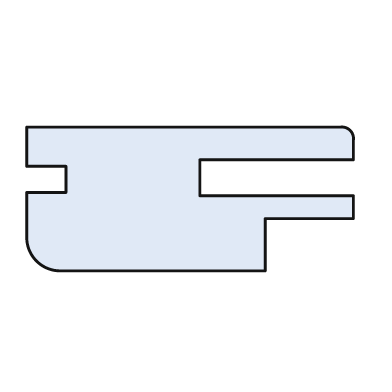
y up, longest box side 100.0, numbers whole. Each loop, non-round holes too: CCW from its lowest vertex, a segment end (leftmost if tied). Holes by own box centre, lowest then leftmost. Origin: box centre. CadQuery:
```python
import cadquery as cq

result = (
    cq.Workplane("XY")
    .moveTo(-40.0, -22.0)
    .lineTo(23.0, -22.0)
    .lineTo(23.0, -6.0)
    .lineTo(50.0, -6.0)
    .lineTo(50.0, 1.0)
    .lineTo(3.0, 1.0)
    .lineTo(3.0, 12.0)
    .lineTo(50.0, 12.0)
    .lineTo(50.0, 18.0)
    .threePointArc((49.0, 21.0), (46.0, 22.0))
    .lineTo(-50.0, 22.0)
    .lineTo(-50.0, 10.0)
    .lineTo(-38.0, 10.0)
    .lineTo(-38.0, 2.0)
    .lineTo(-50.0, 2.0)
    .lineTo(-50.0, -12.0)
    .threePointArc((-47.0, -19.0), (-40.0, -22.0))
    .close()
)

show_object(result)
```